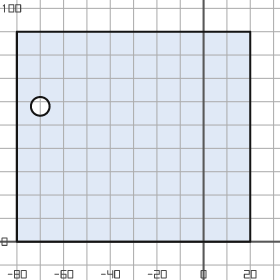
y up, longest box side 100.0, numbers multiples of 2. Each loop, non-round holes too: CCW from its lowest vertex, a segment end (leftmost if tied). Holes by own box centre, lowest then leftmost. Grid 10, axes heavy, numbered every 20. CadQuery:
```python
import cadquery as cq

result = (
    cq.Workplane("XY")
    .moveTo(-80.0, 0.0)
    .lineTo(20.0, 0.0)
    .lineTo(20.0, 90.0)
    .lineTo(-80.0, 90.0)
    .close()
    .moveTo(-70.0, 58.0)
    .circle(4.0)
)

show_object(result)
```